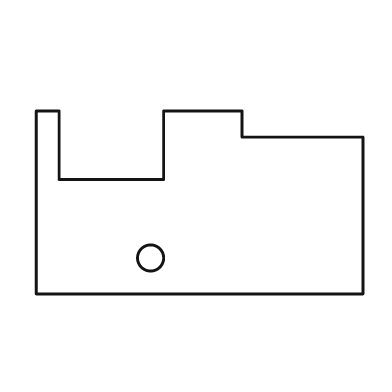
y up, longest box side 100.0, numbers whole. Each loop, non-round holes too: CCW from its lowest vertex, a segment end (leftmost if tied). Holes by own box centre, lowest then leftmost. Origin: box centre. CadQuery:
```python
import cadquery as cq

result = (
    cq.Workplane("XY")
    .moveTo(-50.0, -28.0)
    .lineTo(50.0, -28.0)
    .lineTo(50.0, 20.0)
    .lineTo(13.0, 20.0)
    .lineTo(13.0, 28.0)
    .lineTo(-11.0, 28.0)
    .lineTo(-11.0, 7.0)
    .lineTo(-43.0, 7.0)
    .lineTo(-43.0, 28.0)
    .lineTo(-50.0, 28.0)
    .close()
    .moveTo(-15.0, -17.0)
    .circle(4.0)
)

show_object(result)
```